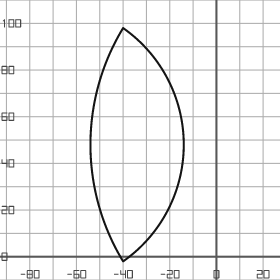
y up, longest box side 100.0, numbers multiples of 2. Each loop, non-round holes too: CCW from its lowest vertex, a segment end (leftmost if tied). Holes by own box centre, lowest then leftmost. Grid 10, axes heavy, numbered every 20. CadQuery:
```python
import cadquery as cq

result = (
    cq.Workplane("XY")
    .moveTo(-40.0, -2.0)
    .threePointArc((-14.0, 48.0), (-40.0, 98.0))
    .threePointArc((-54.0, 48.0), (-40.0, -2.0))
    .close()
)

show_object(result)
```